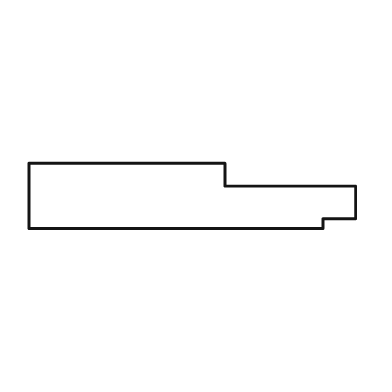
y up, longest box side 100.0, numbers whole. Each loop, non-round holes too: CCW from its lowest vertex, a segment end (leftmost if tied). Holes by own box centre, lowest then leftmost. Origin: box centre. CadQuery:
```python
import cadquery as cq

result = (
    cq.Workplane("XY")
    .moveTo(-50.0, -10.0)
    .lineTo(40.0, -10.0)
    .lineTo(40.0, -7.0)
    .lineTo(50.0, -7.0)
    .lineTo(50.0, 3.0)
    .lineTo(10.0, 3.0)
    .lineTo(10.0, 10.0)
    .lineTo(-50.0, 10.0)
    .close()
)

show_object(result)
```